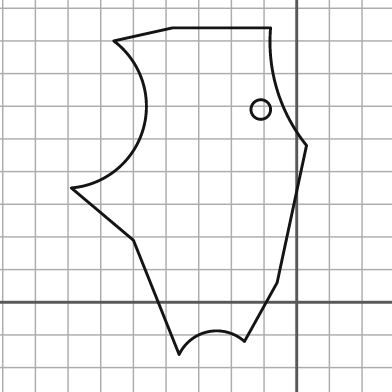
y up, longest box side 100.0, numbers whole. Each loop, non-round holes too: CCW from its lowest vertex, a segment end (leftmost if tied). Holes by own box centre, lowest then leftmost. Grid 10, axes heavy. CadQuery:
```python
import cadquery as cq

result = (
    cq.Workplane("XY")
    .moveTo(-36.0, -16.0)
    .threePointArc((-27.0, -9.0), (-16.0, -12.0))
    .lineTo(-6.0, 6.0)
    .lineTo(3.0, 48.0)
    .threePointArc((-6.0, 65.0), (-8.0, 84.0))
    .lineTo(-38.0, 84.0)
    .lineTo(-56.0, 80.0)
    .threePointArc((-47.0, 53.0), (-69.0, 35.0))
    .lineTo(-50.0, 19.0)
    .close()
    .moveTo(-11.0, 59.0)
    .circle(3.0)
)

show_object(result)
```